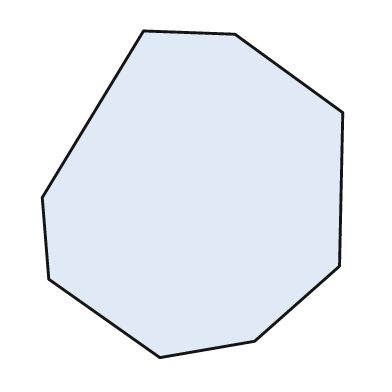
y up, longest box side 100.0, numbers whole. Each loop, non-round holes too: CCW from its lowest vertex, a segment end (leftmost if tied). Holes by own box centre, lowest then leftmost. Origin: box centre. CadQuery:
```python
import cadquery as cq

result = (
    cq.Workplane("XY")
    .moveTo(-10.0, -50.0)
    .lineTo(19.0, -45.0)
    .lineTo(45.0, -22.0)
    .lineTo(46.0, 25.0)
    .lineTo(13.0, 49.0)
    .lineTo(-15.0, 50.0)
    .lineTo(-46.0, -1.0)
    .lineTo(-44.0, -26.0)
    .close()
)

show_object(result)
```